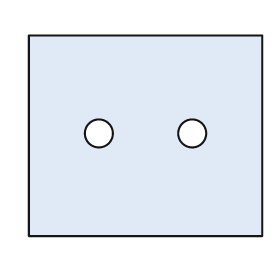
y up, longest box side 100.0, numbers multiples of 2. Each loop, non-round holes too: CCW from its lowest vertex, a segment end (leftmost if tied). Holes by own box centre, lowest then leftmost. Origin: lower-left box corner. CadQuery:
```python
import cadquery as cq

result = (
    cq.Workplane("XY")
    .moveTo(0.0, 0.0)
    .lineTo(100.0, 0.0)
    .lineTo(100.0, 86.0)
    .lineTo(0.0, 86.0)
    .close()
    .moveTo(30.0, 44.0)
    .circle(6.0)
    .moveTo(70.0, 44.0)
    .circle(6.0)
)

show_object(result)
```